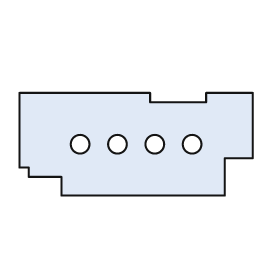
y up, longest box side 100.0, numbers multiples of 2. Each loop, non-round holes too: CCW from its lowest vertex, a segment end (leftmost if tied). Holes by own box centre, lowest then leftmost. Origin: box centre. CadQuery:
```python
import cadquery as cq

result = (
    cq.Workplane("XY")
    .moveTo(-32.0, -22.0)
    .lineTo(38.0, -22.0)
    .lineTo(38.0, -6.0)
    .lineTo(50.0, -6.0)
    .lineTo(50.0, 22.0)
    .lineTo(30.0, 22.0)
    .lineTo(30.0, 18.0)
    .lineTo(6.0, 18.0)
    .lineTo(6.0, 22.0)
    .lineTo(-50.0, 22.0)
    .lineTo(-50.0, -10.0)
    .lineTo(-46.0, -10.0)
    .lineTo(-46.0, -14.0)
    .lineTo(-32.0, -14.0)
    .close()
    .moveTo(-24.0, 0.0)
    .circle(4.0)
    .moveTo(-8.0, 0.0)
    .circle(4.0)
    .moveTo(8.0, 0.0)
    .circle(4.0)
    .moveTo(24.0, 0.0)
    .circle(4.0)
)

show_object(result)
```